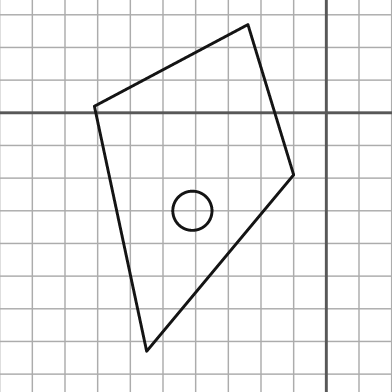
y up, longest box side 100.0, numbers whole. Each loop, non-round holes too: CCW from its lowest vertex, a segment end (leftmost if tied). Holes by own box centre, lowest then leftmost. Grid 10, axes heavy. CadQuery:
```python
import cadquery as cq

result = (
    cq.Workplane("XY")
    .moveTo(-55.0, -73.0)
    .lineTo(-10.0, -19.0)
    .lineTo(-24.0, 27.0)
    .lineTo(-71.0, 2.0)
    .close()
    .moveTo(-41.0, -30.0)
    .circle(6.0)
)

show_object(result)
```